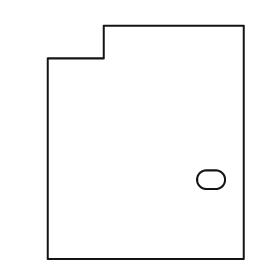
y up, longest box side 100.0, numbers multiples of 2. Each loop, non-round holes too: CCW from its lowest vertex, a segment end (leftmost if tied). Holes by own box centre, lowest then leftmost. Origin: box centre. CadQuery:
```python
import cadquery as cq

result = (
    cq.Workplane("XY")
    .moveTo(-42.0, -50.0)
    .lineTo(42.0, -50.0)
    .lineTo(42.0, 50.0)
    .lineTo(-18.0, 50.0)
    .lineTo(-18.0, 36.0)
    .lineTo(-42.0, 36.0)
    .close()
    .moveTo(26.0, -20.0)
    .lineTo(30.0, -20.0)
    .threePointArc((34.0, -16.0), (30.0, -12.0))
    .lineTo(26.0, -12.0)
    .threePointArc((22.0, -16.0), (26.0, -20.0))
    .close()
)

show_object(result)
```